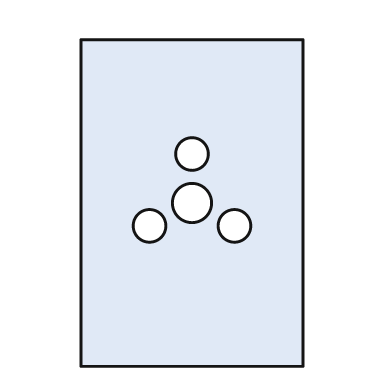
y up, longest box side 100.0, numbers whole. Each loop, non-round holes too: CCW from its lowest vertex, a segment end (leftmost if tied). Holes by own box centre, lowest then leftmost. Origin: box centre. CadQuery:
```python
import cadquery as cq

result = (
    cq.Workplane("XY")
    .moveTo(-34.0, -50.0)
    .lineTo(34.0, -50.0)
    .lineTo(34.0, 50.0)
    .lineTo(-34.0, 50.0)
    .close()
    .moveTo(-13.0, -7.0)
    .circle(5.0)
    .moveTo(13.0, -7.0)
    .circle(5.0)
    .moveTo(0.0, 0.0)
    .circle(6.0)
    .moveTo(0.0, 15.0)
    .circle(5.0)
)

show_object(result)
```